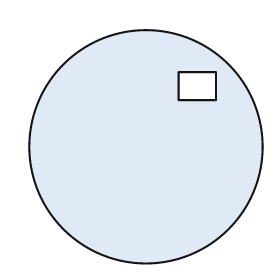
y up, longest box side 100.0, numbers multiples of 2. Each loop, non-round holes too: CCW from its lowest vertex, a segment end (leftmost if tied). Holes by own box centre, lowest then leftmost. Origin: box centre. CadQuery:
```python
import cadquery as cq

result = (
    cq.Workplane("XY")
    .moveTo(0.0, 0.0)
    .circle(50.0)
    .moveTo(14.0, 20.0)
    .lineTo(30.0, 20.0)
    .lineTo(30.0, 32.0)
    .lineTo(14.0, 32.0)
    .close()
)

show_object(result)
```